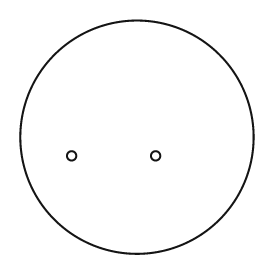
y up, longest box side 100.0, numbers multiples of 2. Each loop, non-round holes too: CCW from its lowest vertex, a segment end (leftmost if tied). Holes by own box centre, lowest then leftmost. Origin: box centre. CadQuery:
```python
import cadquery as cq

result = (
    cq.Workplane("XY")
    .moveTo(0.0, 0.0)
    .circle(50.0)
    .moveTo(-28.0, -8.0)
    .circle(2.0)
    .moveTo(8.0, -8.0)
    .circle(2.0)
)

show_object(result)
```